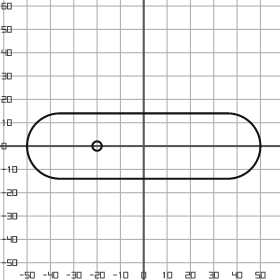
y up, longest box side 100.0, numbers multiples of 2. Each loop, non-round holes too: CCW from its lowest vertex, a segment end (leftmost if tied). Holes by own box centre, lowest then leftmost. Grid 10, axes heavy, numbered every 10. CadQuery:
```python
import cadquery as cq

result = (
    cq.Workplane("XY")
    .moveTo(-36.0, -14.0)
    .lineTo(36.0, -14.0)
    .threePointArc((50.0, 0.0), (36.0, 14.0))
    .lineTo(-36.0, 14.0)
    .threePointArc((-50.0, 0.0), (-36.0, -14.0))
    .close()
    .moveTo(-20.0, 0.0)
    .circle(2.0)
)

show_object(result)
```